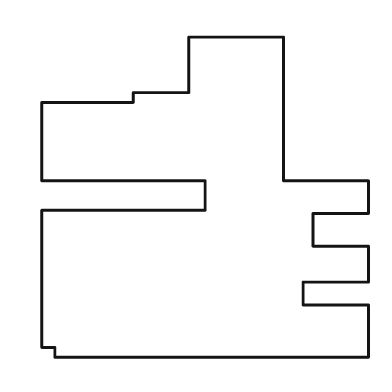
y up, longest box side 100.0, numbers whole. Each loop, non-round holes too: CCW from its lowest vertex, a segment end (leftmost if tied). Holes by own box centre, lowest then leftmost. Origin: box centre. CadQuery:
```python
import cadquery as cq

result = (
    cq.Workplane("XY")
    .moveTo(-46.0, -49.0)
    .lineTo(50.0, -49.0)
    .lineTo(50.0, -33.0)
    .lineTo(30.0, -33.0)
    .lineTo(30.0, -26.0)
    .lineTo(50.0, -26.0)
    .lineTo(50.0, -15.0)
    .lineTo(33.0, -15.0)
    .lineTo(33.0, -5.0)
    .lineTo(50.0, -5.0)
    .lineTo(50.0, 5.0)
    .lineTo(24.0, 5.0)
    .lineTo(24.0, 49.0)
    .lineTo(-5.0, 49.0)
    .lineTo(-5.0, 32.0)
    .lineTo(-22.0, 32.0)
    .lineTo(-22.0, 29.0)
    .lineTo(-50.0, 29.0)
    .lineTo(-50.0, 5.0)
    .lineTo(0.0, 5.0)
    .lineTo(0.0, -4.0)
    .lineTo(-50.0, -4.0)
    .lineTo(-50.0, -46.0)
    .lineTo(-46.0, -46.0)
    .close()
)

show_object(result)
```